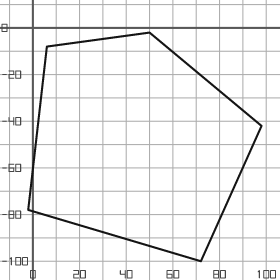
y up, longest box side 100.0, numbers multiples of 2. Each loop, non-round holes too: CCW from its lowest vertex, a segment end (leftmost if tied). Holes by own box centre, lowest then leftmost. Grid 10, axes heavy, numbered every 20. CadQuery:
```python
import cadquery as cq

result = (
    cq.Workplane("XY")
    .moveTo(72.0, -100.0)
    .lineTo(98.0, -42.0)
    .lineTo(50.0, -2.0)
    .lineTo(6.0, -8.0)
    .lineTo(-2.0, -78.0)
    .close()
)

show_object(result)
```